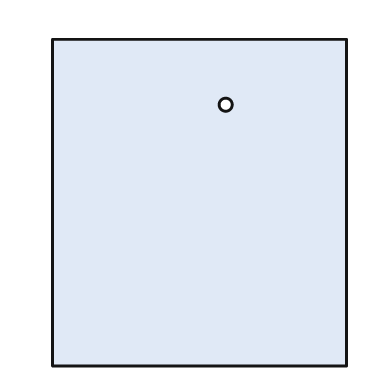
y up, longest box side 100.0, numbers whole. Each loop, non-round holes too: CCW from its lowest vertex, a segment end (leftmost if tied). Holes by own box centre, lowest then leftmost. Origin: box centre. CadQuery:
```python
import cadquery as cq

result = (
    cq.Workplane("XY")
    .moveTo(-45.0, -50.0)
    .lineTo(45.0, -50.0)
    .lineTo(45.0, 50.0)
    .lineTo(-45.0, 50.0)
    .close()
    .moveTo(8.0, 30.0)
    .circle(2.0)
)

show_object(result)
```